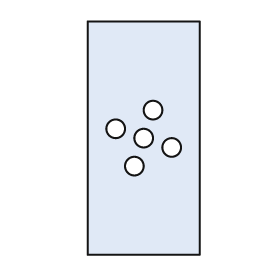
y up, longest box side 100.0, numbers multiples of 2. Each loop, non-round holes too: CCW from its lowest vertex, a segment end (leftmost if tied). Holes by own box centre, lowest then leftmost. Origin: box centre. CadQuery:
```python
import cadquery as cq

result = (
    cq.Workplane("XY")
    .moveTo(-24.0, -50.0)
    .lineTo(24.0, -50.0)
    .lineTo(24.0, 50.0)
    .lineTo(-24.0, 50.0)
    .close()
    .moveTo(-4.0, -12.0)
    .circle(4.0)
    .moveTo(12.0, -4.0)
    .circle(4.0)
    .moveTo(0.0, 0.0)
    .circle(4.0)
    .moveTo(-12.0, 4.0)
    .circle(4.0)
    .moveTo(4.0, 12.0)
    .circle(4.0)
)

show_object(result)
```